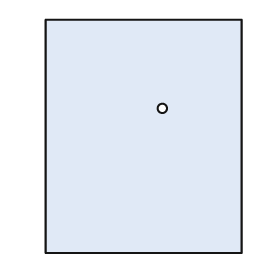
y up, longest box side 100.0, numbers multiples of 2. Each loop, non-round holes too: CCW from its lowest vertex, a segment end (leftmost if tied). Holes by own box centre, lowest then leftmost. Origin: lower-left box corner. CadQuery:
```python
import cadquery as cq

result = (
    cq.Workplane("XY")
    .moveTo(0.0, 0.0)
    .lineTo(84.0, 0.0)
    .lineTo(84.0, 100.0)
    .lineTo(0.0, 100.0)
    .close()
    .moveTo(50.0, 62.0)
    .circle(2.0)
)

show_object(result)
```